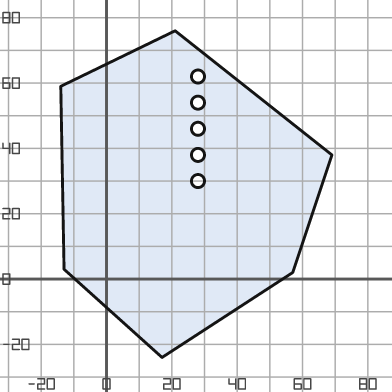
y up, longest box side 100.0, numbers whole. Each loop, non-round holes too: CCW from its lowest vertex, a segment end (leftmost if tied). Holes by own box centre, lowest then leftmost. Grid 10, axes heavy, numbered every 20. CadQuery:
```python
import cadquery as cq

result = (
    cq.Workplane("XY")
    .moveTo(17.0, -24.0)
    .lineTo(57.0, 2.0)
    .lineTo(69.0, 38.0)
    .lineTo(21.0, 76.0)
    .lineTo(-14.0, 59.0)
    .lineTo(-13.0, 3.0)
    .close()
    .moveTo(28.0, 30.0)
    .circle(2.0)
    .moveTo(28.0, 38.0)
    .circle(2.0)
    .moveTo(28.0, 46.0)
    .circle(2.0)
    .moveTo(28.0, 54.0)
    .circle(2.0)
    .moveTo(28.0, 62.0)
    .circle(2.0)
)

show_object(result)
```